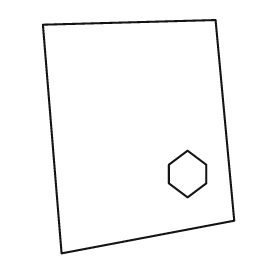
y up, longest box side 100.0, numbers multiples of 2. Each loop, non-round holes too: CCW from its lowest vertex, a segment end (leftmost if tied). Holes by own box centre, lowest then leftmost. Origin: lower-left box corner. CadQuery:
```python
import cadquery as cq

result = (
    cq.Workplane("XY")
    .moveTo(8.0, 0.0)
    .lineTo(82.0, 14.0)
    .lineTo(74.0, 100.0)
    .lineTo(0.0, 98.0)
    .close()
    .moveTo(62.0, 24.0)
    .lineTo(70.0, 30.0)
    .lineTo(70.0, 38.0)
    .lineTo(62.0, 44.0)
    .lineTo(54.0, 38.0)
    .lineTo(54.0, 30.0)
    .close()
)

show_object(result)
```